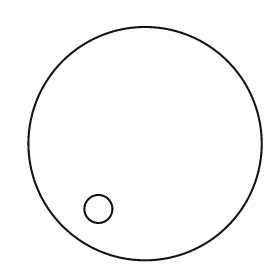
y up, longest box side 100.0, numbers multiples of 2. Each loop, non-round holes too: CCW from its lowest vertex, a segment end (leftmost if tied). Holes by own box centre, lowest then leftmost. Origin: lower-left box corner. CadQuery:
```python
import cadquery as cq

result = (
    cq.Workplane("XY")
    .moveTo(50.0, 50.0)
    .circle(50.0)
    .moveTo(30.0, 22.0)
    .circle(6.0)
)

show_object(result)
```